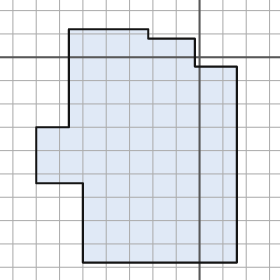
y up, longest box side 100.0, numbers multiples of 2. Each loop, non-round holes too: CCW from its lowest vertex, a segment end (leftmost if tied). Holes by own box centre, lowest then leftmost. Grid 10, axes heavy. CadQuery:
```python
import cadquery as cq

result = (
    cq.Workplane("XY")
    .moveTo(-50.0, -88.0)
    .lineTo(16.0, -88.0)
    .lineTo(16.0, -4.0)
    .lineTo(-2.0, -4.0)
    .lineTo(-2.0, 8.0)
    .lineTo(-22.0, 8.0)
    .lineTo(-22.0, 12.0)
    .lineTo(-56.0, 12.0)
    .lineTo(-56.0, -30.0)
    .lineTo(-70.0, -30.0)
    .lineTo(-70.0, -54.0)
    .lineTo(-50.0, -54.0)
    .close()
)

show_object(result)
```